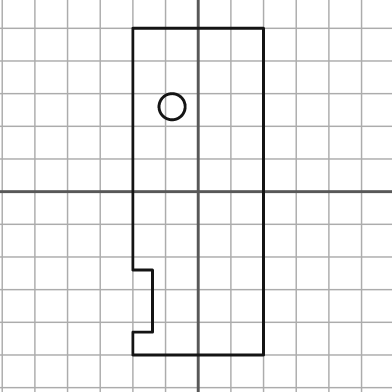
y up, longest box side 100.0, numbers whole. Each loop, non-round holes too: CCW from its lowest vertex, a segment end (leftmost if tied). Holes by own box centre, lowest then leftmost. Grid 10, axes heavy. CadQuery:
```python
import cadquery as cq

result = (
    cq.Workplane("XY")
    .moveTo(-20.0, -50.0)
    .lineTo(20.0, -50.0)
    .lineTo(20.0, 50.0)
    .lineTo(-20.0, 50.0)
    .lineTo(-20.0, -24.0)
    .lineTo(-14.0, -24.0)
    .lineTo(-14.0, -43.0)
    .lineTo(-20.0, -43.0)
    .close()
    .moveTo(-8.0, 26.0)
    .circle(4.0)
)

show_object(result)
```